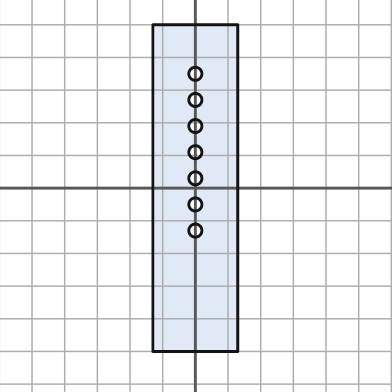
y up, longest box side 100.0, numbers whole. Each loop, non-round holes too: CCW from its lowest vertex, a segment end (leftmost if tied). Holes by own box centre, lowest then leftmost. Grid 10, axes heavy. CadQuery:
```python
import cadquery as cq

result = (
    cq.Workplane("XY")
    .moveTo(-13.0, -50.0)
    .lineTo(13.0, -50.0)
    .lineTo(13.0, 50.0)
    .lineTo(-13.0, 50.0)
    .close()
    .moveTo(0.0, -13.0)
    .circle(2.0)
    .moveTo(0.0, -5.0)
    .circle(2.0)
    .moveTo(0.0, 3.0)
    .circle(2.0)
    .moveTo(0.0, 11.0)
    .circle(2.0)
    .moveTo(0.0, 19.0)
    .circle(2.0)
    .moveTo(0.0, 27.0)
    .circle(2.0)
    .moveTo(0.0, 35.0)
    .circle(2.0)
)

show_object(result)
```